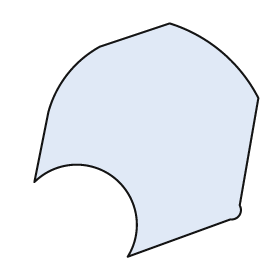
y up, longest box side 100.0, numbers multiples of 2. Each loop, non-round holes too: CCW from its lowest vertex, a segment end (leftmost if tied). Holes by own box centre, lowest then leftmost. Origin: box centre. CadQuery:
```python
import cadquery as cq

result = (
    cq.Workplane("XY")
    .moveTo(-8.0, -50.0)
    .lineTo(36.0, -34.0)
    .threePointArc((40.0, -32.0), (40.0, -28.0))
    .lineTo(48.0, 18.0)
    .threePointArc((32.0, 38.0), (10.0, 50.0))
    .lineTo(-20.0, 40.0)
    .threePointArc((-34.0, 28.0), (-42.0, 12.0))
    .lineTo(-48.0, -18.0)
    .threePointArc((-14.0, -16.0), (-8.0, -50.0))
    .close()
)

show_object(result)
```